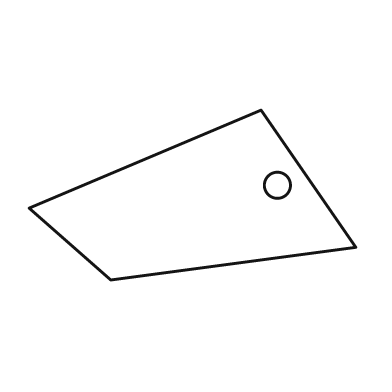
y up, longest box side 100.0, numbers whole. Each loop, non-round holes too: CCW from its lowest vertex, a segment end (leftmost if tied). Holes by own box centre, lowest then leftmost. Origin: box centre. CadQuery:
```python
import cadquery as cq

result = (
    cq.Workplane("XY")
    .moveTo(-25.0, -26.0)
    .lineTo(50.0, -16.0)
    .lineTo(21.0, 26.0)
    .lineTo(-50.0, -4.0)
    .close()
    .moveTo(26.0, 3.0)
    .circle(4.0)
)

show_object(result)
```